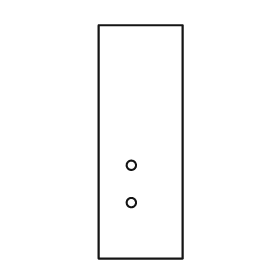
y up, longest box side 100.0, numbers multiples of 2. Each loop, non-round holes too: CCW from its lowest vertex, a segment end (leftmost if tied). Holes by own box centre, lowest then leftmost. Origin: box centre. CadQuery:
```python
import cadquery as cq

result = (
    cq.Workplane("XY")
    .moveTo(-18.0, -50.0)
    .lineTo(18.0, -50.0)
    .lineTo(18.0, 50.0)
    .lineTo(-18.0, 50.0)
    .close()
    .moveTo(-4.0, -26.0)
    .circle(2.0)
    .moveTo(-4.0, -10.0)
    .circle(2.0)
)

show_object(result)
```